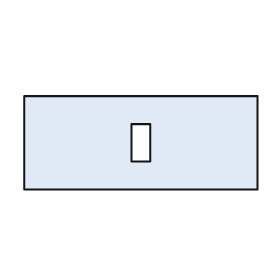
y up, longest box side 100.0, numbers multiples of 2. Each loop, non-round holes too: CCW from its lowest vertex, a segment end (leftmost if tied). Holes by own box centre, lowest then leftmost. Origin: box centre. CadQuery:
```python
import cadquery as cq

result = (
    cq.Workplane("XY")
    .moveTo(-50.0, -20.0)
    .lineTo(50.0, -20.0)
    .lineTo(50.0, 20.0)
    .lineTo(-50.0, 20.0)
    .close()
    .moveTo(-4.0, -8.0)
    .lineTo(4.0, -8.0)
    .lineTo(4.0, 8.0)
    .lineTo(-4.0, 8.0)
    .close()
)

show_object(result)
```